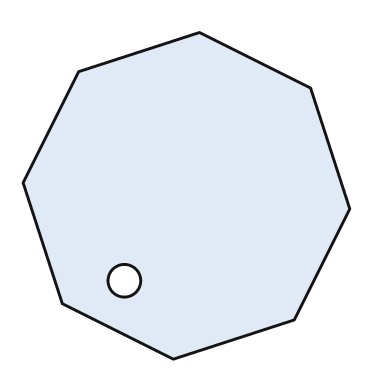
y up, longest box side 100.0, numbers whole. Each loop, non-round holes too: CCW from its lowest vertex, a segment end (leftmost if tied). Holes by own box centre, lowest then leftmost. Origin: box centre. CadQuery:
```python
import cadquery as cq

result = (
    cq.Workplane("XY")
    .moveTo(-4.0, -50.0)
    .lineTo(33.0, -38.0)
    .lineTo(50.0, -4.0)
    .lineTo(38.0, 33.0)
    .lineTo(4.0, 50.0)
    .lineTo(-33.0, 38.0)
    .lineTo(-50.0, 4.0)
    .lineTo(-38.0, -33.0)
    .close()
    .moveTo(-19.0, -26.0)
    .circle(5.0)
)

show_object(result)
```